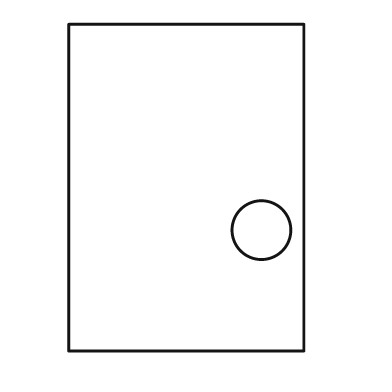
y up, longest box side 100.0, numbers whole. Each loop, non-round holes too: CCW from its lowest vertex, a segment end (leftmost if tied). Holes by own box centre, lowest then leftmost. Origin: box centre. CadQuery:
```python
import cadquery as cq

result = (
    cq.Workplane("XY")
    .moveTo(-36.0, -50.0)
    .lineTo(36.0, -50.0)
    .lineTo(36.0, 50.0)
    .lineTo(-36.0, 50.0)
    .close()
    .moveTo(23.0, -13.0)
    .circle(9.0)
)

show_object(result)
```